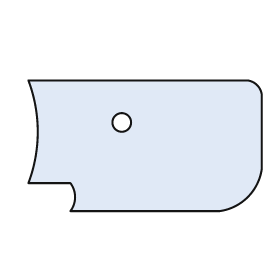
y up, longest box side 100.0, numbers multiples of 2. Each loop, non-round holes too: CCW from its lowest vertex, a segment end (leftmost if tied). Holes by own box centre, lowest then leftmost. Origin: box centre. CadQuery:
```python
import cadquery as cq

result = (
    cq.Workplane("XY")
    .moveTo(-32.0, -28.0)
    .lineTo(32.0, -28.0)
    .threePointArc((44.0, -22.0), (50.0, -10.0))
    .lineTo(50.0, 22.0)
    .threePointArc((48.0, 26.0), (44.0, 28.0))
    .lineTo(-50.0, 28.0)
    .threePointArc((-46.0, 6.0), (-50.0, -16.0))
    .lineTo(-32.0, -16.0)
    .threePointArc((-30.0, -22.0), (-32.0, -28.0))
    .close()
    .moveTo(-10.0, 10.0)
    .circle(4.0)
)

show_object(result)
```